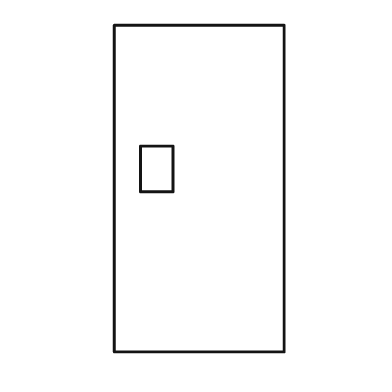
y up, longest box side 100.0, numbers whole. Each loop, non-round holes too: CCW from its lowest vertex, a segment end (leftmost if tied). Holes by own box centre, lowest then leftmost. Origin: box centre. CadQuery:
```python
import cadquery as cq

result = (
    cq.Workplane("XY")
    .moveTo(-26.0, -50.0)
    .lineTo(26.0, -50.0)
    .lineTo(26.0, 50.0)
    .lineTo(-26.0, 50.0)
    .close()
    .moveTo(-18.0, -1.0)
    .lineTo(-8.0, -1.0)
    .lineTo(-8.0, 13.0)
    .lineTo(-18.0, 13.0)
    .close()
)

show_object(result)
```